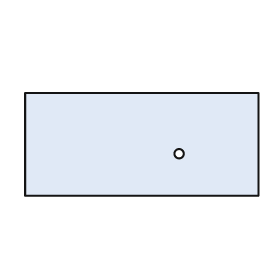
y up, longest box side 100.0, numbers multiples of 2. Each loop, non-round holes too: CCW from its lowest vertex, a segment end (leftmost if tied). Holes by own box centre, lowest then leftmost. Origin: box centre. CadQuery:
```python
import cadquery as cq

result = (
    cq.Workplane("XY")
    .moveTo(-50.0, -22.0)
    .lineTo(50.0, -22.0)
    .lineTo(50.0, 22.0)
    .lineTo(-50.0, 22.0)
    .close()
    .moveTo(16.0, -4.0)
    .circle(2.0)
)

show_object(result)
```